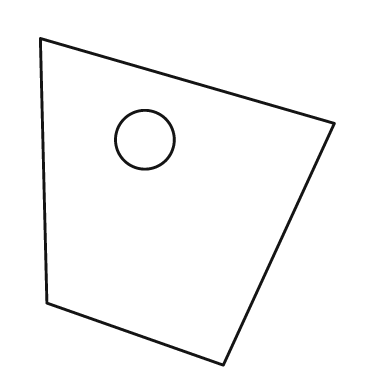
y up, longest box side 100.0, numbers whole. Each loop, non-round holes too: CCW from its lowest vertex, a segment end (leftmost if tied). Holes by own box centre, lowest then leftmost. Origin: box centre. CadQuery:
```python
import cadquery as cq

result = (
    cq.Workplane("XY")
    .moveTo(11.0, -50.0)
    .lineTo(45.0, 24.0)
    .lineTo(-45.0, 50.0)
    .lineTo(-43.0, -31.0)
    .close()
    .moveTo(-13.0, 19.0)
    .circle(9.0)
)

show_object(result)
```